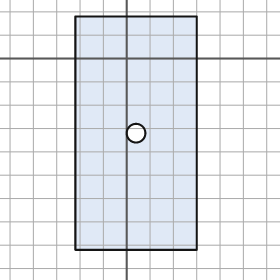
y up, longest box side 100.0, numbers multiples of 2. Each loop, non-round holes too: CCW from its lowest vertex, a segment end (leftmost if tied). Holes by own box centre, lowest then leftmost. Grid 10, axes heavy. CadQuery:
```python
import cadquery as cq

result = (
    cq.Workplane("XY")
    .moveTo(-22.0, -82.0)
    .lineTo(30.0, -82.0)
    .lineTo(30.0, 18.0)
    .lineTo(-22.0, 18.0)
    .close()
    .moveTo(4.0, -32.0)
    .circle(4.0)
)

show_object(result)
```